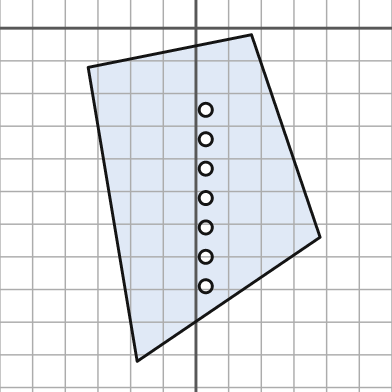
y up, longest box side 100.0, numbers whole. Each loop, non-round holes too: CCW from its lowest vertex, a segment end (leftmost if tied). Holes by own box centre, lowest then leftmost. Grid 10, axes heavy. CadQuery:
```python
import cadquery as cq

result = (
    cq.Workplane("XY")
    .moveTo(-18.0, -102.0)
    .lineTo(38.0, -64.0)
    .lineTo(17.0, -2.0)
    .lineTo(-33.0, -12.0)
    .close()
    .moveTo(3.0, -79.0)
    .circle(2.0)
    .moveTo(3.0, -70.0)
    .circle(2.0)
    .moveTo(3.0, -61.0)
    .circle(2.0)
    .moveTo(3.0, -52.0)
    .circle(2.0)
    .moveTo(3.0, -43.0)
    .circle(2.0)
    .moveTo(3.0, -34.0)
    .circle(2.0)
    .moveTo(3.0, -25.0)
    .circle(2.0)
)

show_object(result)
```